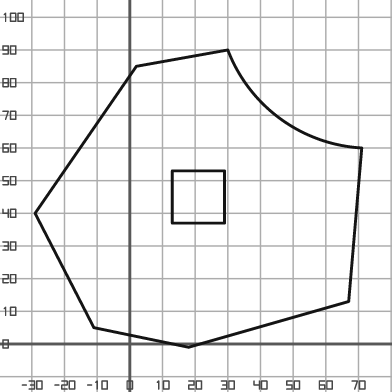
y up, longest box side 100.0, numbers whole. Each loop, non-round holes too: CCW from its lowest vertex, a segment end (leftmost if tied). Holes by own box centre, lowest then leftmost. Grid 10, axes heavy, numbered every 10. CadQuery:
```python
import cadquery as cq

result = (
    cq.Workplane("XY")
    .moveTo(18.0, -1.0)
    .lineTo(67.0, 13.0)
    .lineTo(71.0, 60.0)
    .threePointArc((46.0, 69.0), (30.0, 90.0))
    .lineTo(2.0, 85.0)
    .lineTo(-29.0, 40.0)
    .lineTo(-11.0, 5.0)
    .close()
    .moveTo(13.0, 37.0)
    .lineTo(29.0, 37.0)
    .lineTo(29.0, 53.0)
    .lineTo(13.0, 53.0)
    .close()
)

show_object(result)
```